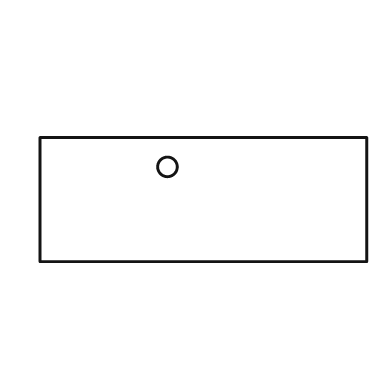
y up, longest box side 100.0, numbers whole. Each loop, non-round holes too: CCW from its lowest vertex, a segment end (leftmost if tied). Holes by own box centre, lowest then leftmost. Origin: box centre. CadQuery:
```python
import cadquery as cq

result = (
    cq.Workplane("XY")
    .moveTo(-50.0, -19.0)
    .lineTo(50.0, -19.0)
    .lineTo(50.0, 19.0)
    .lineTo(-50.0, 19.0)
    .close()
    .moveTo(-11.0, 10.0)
    .circle(3.0)
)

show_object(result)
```